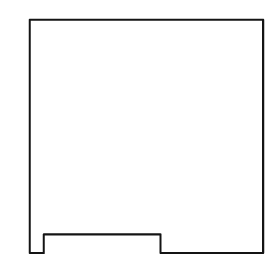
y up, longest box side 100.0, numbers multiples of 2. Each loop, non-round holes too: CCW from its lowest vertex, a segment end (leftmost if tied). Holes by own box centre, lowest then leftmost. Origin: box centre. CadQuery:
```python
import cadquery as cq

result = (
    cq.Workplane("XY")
    .moveTo(-50.0, -50.0)
    .lineTo(-44.0, -50.0)
    .lineTo(-44.0, -42.0)
    .lineTo(6.0, -42.0)
    .lineTo(6.0, -50.0)
    .lineTo(50.0, -50.0)
    .lineTo(50.0, 50.0)
    .lineTo(-50.0, 50.0)
    .close()
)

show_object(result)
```